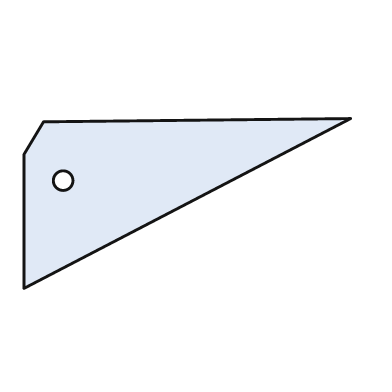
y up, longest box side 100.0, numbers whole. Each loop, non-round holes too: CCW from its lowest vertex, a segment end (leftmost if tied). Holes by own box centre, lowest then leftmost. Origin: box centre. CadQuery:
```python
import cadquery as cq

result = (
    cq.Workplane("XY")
    .moveTo(-50.0, -26.0)
    .lineTo(50.0, 26.0)
    .lineTo(-44.0, 25.0)
    .lineTo(-50.0, 15.0)
    .close()
    .moveTo(-38.0, 7.0)
    .circle(3.0)
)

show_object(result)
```